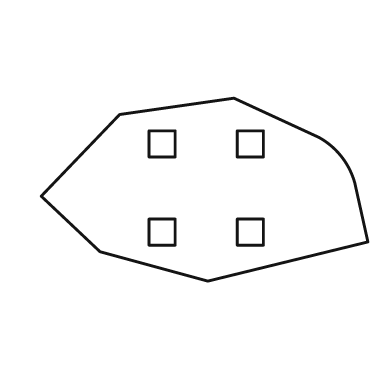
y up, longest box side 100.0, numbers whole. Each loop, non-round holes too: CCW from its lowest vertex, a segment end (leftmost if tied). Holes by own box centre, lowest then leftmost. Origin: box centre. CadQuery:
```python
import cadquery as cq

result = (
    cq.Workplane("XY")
    .moveTo(1.0, -28.0)
    .lineTo(50.0, -16.0)
    .lineTo(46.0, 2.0)
    .threePointArc((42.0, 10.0), (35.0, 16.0))
    .lineTo(9.0, 28.0)
    .lineTo(-26.0, 23.0)
    .lineTo(-50.0, -2.0)
    .lineTo(-32.0, -19.0)
    .close()
    .moveTo(-17.0, -17.0)
    .lineTo(-9.0, -17.0)
    .lineTo(-9.0, -9.0)
    .lineTo(-17.0, -9.0)
    .close()
    .moveTo(10.0, -17.0)
    .lineTo(18.0, -17.0)
    .lineTo(18.0, -9.0)
    .lineTo(10.0, -9.0)
    .close()
    .moveTo(-17.0, 10.0)
    .lineTo(-9.0, 10.0)
    .lineTo(-9.0, 18.0)
    .lineTo(-17.0, 18.0)
    .close()
    .moveTo(10.0, 10.0)
    .lineTo(18.0, 10.0)
    .lineTo(18.0, 18.0)
    .lineTo(10.0, 18.0)
    .close()
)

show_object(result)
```